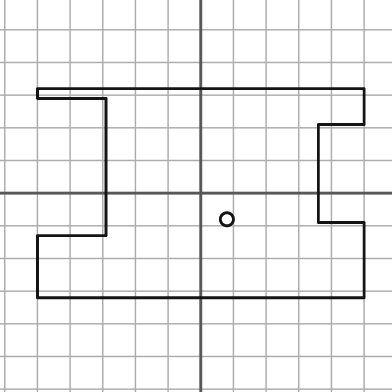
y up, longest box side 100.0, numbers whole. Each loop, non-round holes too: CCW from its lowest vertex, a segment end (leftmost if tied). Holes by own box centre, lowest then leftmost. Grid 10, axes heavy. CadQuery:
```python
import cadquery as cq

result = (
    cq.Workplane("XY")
    .moveTo(-50.0, -32.0)
    .lineTo(50.0, -32.0)
    .lineTo(50.0, -9.0)
    .lineTo(36.0, -9.0)
    .lineTo(36.0, 21.0)
    .lineTo(50.0, 21.0)
    .lineTo(50.0, 32.0)
    .lineTo(-50.0, 32.0)
    .lineTo(-50.0, 29.0)
    .lineTo(-29.0, 29.0)
    .lineTo(-29.0, -13.0)
    .lineTo(-50.0, -13.0)
    .close()
    .moveTo(8.0, -8.0)
    .circle(2.0)
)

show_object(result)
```